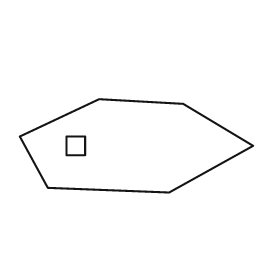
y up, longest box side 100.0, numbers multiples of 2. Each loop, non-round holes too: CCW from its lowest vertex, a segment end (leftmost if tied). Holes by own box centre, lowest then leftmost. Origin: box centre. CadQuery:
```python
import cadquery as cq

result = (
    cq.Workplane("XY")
    .moveTo(14.0, -20.0)
    .lineTo(50.0, 0.0)
    .lineTo(20.0, 18.0)
    .lineTo(-16.0, 20.0)
    .lineTo(-50.0, 4.0)
    .lineTo(-38.0, -18.0)
    .close()
    .moveTo(-30.0, -4.0)
    .lineTo(-22.0, -4.0)
    .lineTo(-22.0, 4.0)
    .lineTo(-30.0, 4.0)
    .close()
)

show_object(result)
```